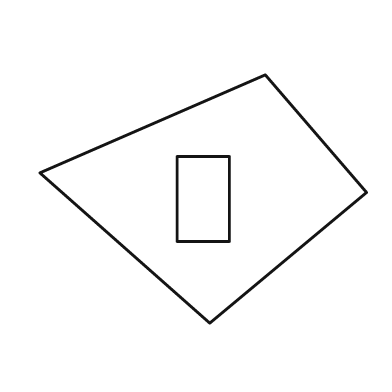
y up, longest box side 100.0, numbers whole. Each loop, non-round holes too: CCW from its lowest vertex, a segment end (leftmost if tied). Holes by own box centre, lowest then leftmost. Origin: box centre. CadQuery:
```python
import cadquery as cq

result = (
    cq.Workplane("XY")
    .moveTo(2.0, -38.0)
    .lineTo(50.0, 2.0)
    .lineTo(19.0, 38.0)
    .lineTo(-50.0, 8.0)
    .close()
    .moveTo(-8.0, -13.0)
    .lineTo(8.0, -13.0)
    .lineTo(8.0, 13.0)
    .lineTo(-8.0, 13.0)
    .close()
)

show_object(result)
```